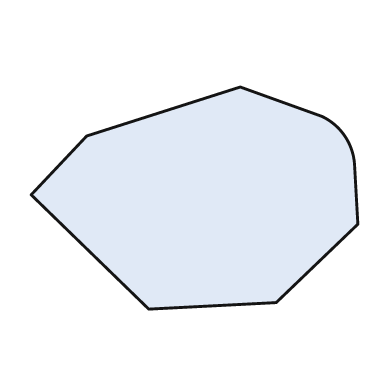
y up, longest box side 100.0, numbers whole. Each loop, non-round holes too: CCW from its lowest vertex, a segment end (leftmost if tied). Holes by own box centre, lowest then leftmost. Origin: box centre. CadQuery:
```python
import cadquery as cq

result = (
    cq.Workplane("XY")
    .moveTo(-14.0, -34.0)
    .lineTo(25.0, -32.0)
    .lineTo(50.0, -8.0)
    .lineTo(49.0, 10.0)
    .threePointArc((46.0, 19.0), (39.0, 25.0))
    .lineTo(14.0, 34.0)
    .lineTo(-33.0, 19.0)
    .lineTo(-50.0, 1.0)
    .close()
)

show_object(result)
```